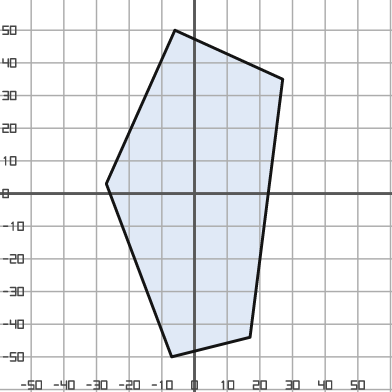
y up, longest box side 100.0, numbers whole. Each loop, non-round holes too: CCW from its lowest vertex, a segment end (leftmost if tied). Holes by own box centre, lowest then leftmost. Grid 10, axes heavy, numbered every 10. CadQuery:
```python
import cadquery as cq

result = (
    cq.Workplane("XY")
    .moveTo(-7.0, -50.0)
    .lineTo(17.0, -44.0)
    .lineTo(27.0, 35.0)
    .lineTo(-6.0, 50.0)
    .lineTo(-27.0, 3.0)
    .close()
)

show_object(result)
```